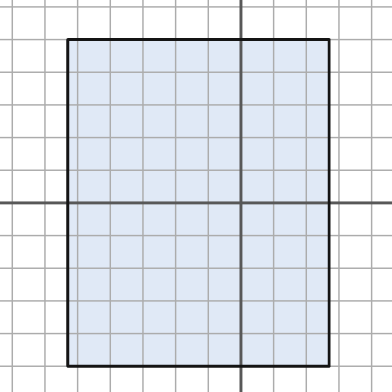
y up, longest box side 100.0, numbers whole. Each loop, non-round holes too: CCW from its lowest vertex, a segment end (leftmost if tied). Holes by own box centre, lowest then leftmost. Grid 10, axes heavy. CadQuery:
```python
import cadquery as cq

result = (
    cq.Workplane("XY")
    .moveTo(-53.0, -50.0)
    .lineTo(27.0, -50.0)
    .lineTo(27.0, 50.0)
    .lineTo(-53.0, 50.0)
    .close()
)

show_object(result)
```